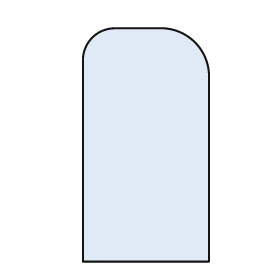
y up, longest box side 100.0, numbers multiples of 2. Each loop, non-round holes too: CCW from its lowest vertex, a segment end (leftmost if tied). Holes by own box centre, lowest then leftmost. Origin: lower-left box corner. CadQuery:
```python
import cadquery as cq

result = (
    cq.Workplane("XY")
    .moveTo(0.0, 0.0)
    .lineTo(54.0, 0.0)
    .lineTo(54.0, 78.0)
    .threePointArc((48.0, 94.0), (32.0, 100.0))
    .lineTo(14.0, 100.0)
    .threePointArc((4.0, 96.0), (0.0, 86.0))
    .close()
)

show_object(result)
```